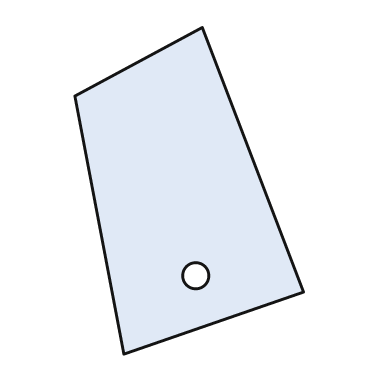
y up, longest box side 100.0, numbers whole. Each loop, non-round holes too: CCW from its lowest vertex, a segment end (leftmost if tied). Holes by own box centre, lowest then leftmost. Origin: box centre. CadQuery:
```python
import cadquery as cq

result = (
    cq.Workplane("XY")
    .moveTo(-20.0, -50.0)
    .lineTo(35.0, -31.0)
    .lineTo(4.0, 50.0)
    .lineTo(-35.0, 29.0)
    .close()
    .moveTo(2.0, -26.0)
    .circle(4.0)
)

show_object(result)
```